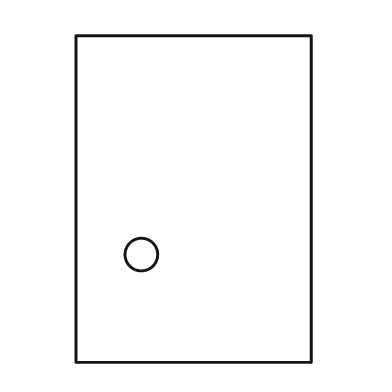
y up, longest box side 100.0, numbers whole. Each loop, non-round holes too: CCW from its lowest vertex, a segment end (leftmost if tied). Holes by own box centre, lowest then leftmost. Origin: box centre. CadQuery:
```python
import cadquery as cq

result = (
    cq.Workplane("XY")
    .moveTo(-36.0, -50.0)
    .lineTo(36.0, -50.0)
    .lineTo(36.0, 50.0)
    .lineTo(-36.0, 50.0)
    .close()
    .moveTo(-16.0, -17.0)
    .circle(5.0)
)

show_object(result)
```